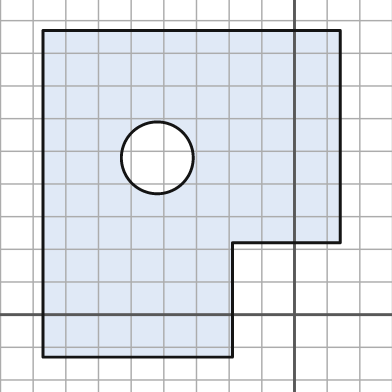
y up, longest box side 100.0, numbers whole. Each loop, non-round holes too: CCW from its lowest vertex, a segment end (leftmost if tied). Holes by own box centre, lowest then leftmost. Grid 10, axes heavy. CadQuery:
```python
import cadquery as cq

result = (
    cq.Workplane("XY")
    .moveTo(-77.0, -13.0)
    .lineTo(-19.0, -13.0)
    .lineTo(-19.0, 22.0)
    .lineTo(14.0, 22.0)
    .lineTo(14.0, 87.0)
    .lineTo(-77.0, 87.0)
    .close()
    .moveTo(-42.0, 48.0)
    .circle(11.0)
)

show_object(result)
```